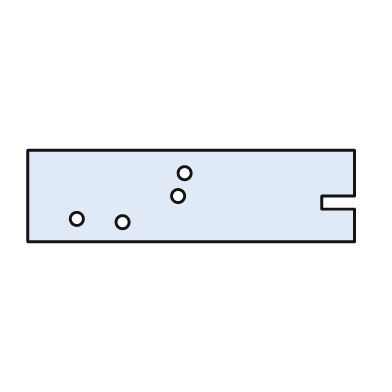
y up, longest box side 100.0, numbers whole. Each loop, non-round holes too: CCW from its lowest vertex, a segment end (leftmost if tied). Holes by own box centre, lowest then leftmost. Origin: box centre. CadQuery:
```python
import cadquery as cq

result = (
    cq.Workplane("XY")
    .moveTo(-50.0, -14.0)
    .lineTo(50.0, -14.0)
    .lineTo(50.0, -4.0)
    .lineTo(40.0, -4.0)
    .lineTo(40.0, 0.0)
    .lineTo(50.0, 0.0)
    .lineTo(50.0, 14.0)
    .lineTo(-50.0, 14.0)
    .close()
    .moveTo(-21.0, -8.0)
    .circle(2.0)
    .moveTo(-35.0, -7.0)
    .circle(2.0)
    .moveTo(-4.0, 0.0)
    .circle(2.0)
    .moveTo(-2.0, 7.0)
    .circle(2.0)
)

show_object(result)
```